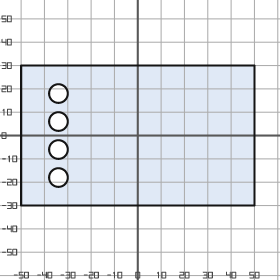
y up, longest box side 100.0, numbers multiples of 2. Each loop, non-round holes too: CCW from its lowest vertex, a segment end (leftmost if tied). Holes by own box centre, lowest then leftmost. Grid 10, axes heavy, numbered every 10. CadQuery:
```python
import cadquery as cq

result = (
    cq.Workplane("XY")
    .moveTo(-50.0, -30.0)
    .lineTo(50.0, -30.0)
    .lineTo(50.0, 30.0)
    .lineTo(-50.0, 30.0)
    .close()
    .moveTo(-34.0, -18.0)
    .circle(4.0)
    .moveTo(-34.0, -6.0)
    .circle(4.0)
    .moveTo(-34.0, 6.0)
    .circle(4.0)
    .moveTo(-34.0, 18.0)
    .circle(4.0)
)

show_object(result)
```